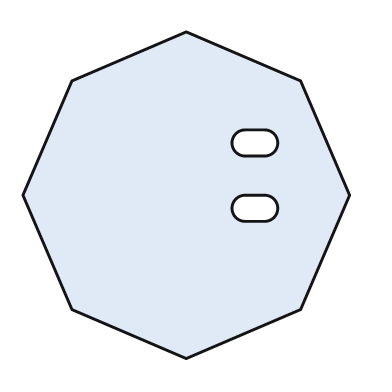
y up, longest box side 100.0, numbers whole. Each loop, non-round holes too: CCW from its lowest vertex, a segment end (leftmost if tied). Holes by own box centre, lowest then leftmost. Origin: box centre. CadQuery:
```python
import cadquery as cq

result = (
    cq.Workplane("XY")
    .moveTo(0.0, -50.0)
    .lineTo(35.0, -35.0)
    .lineTo(50.0, 0.0)
    .lineTo(35.0, 35.0)
    .lineTo(0.0, 50.0)
    .lineTo(-35.0, 35.0)
    .lineTo(-50.0, 0.0)
    .lineTo(-35.0, -35.0)
    .close()
    .moveTo(18.0, -8.0)
    .lineTo(24.0, -8.0)
    .threePointArc((28.0, -4.0), (24.0, 0.0))
    .lineTo(18.0, 0.0)
    .threePointArc((14.0, -4.0), (18.0, -8.0))
    .close()
    .moveTo(18.0, 12.0)
    .lineTo(24.0, 12.0)
    .threePointArc((28.0, 16.0), (24.0, 20.0))
    .lineTo(18.0, 20.0)
    .threePointArc((14.0, 16.0), (18.0, 12.0))
    .close()
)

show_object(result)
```